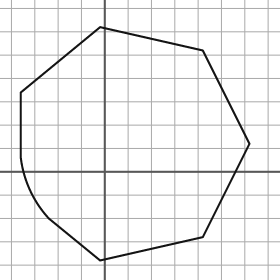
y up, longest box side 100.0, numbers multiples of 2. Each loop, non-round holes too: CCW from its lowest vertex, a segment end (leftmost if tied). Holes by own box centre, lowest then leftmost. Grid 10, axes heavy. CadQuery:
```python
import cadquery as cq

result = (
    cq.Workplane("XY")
    .moveTo(-2.0, -38.0)
    .lineTo(42.0, -28.0)
    .lineTo(62.0, 12.0)
    .lineTo(42.0, 52.0)
    .lineTo(-2.0, 62.0)
    .lineTo(-36.0, 34.0)
    .lineTo(-36.0, 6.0)
    .threePointArc((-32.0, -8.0), (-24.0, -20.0))
    .close()
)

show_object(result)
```